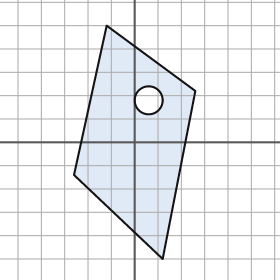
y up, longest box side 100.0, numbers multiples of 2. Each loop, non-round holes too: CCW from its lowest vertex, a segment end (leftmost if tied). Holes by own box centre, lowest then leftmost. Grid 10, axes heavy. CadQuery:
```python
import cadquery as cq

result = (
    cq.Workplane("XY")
    .moveTo(12.0, -50.0)
    .lineTo(26.0, 22.0)
    .lineTo(-12.0, 50.0)
    .lineTo(-26.0, -14.0)
    .close()
    .moveTo(6.0, 18.0)
    .circle(6.0)
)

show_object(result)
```